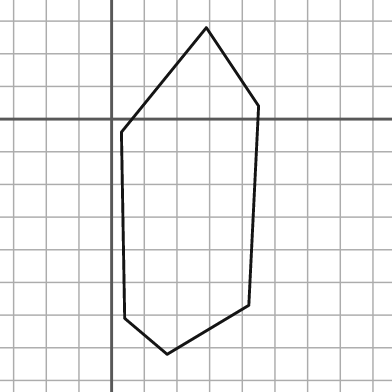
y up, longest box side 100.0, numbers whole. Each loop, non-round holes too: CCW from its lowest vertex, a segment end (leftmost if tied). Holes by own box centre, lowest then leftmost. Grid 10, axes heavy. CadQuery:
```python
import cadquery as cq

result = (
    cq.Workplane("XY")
    .moveTo(17.0, -72.0)
    .lineTo(42.0, -57.0)
    .lineTo(45.0, 4.0)
    .lineTo(29.0, 28.0)
    .lineTo(3.0, -4.0)
    .lineTo(4.0, -61.0)
    .close()
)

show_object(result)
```